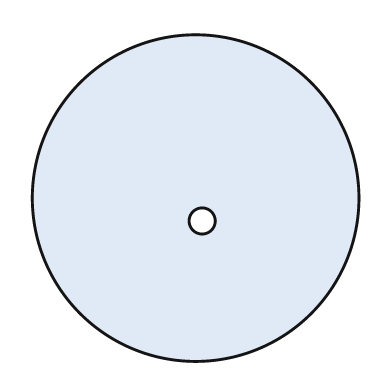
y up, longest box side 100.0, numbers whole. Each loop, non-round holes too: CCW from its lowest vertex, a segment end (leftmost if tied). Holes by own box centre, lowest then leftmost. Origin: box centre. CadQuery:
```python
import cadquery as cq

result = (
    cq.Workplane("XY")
    .moveTo(0.0, 0.0)
    .circle(50.0)
    .moveTo(2.0, -7.0)
    .circle(4.0)
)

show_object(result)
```